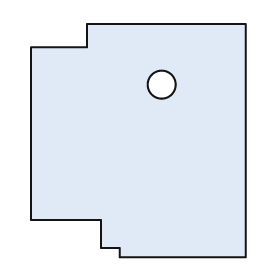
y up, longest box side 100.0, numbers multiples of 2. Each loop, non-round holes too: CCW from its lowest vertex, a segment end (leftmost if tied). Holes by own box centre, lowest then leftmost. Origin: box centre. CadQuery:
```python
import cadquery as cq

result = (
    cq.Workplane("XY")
    .moveTo(-8.0, -50.0)
    .lineTo(46.0, -50.0)
    .lineTo(46.0, 50.0)
    .lineTo(-22.0, 50.0)
    .lineTo(-22.0, 40.0)
    .lineTo(-46.0, 40.0)
    .lineTo(-46.0, -34.0)
    .lineTo(-16.0, -34.0)
    .lineTo(-16.0, -46.0)
    .lineTo(-8.0, -46.0)
    .close()
    .moveTo(10.0, 24.0)
    .circle(6.0)
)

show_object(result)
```